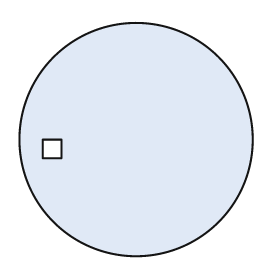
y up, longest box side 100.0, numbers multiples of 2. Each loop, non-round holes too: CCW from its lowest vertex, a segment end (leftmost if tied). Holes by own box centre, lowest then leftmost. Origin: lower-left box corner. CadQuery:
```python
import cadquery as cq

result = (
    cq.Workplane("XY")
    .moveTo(50.0, 50.0)
    .circle(50.0)
    .moveTo(10.0, 42.0)
    .lineTo(18.0, 42.0)
    .lineTo(18.0, 50.0)
    .lineTo(10.0, 50.0)
    .close()
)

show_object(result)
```